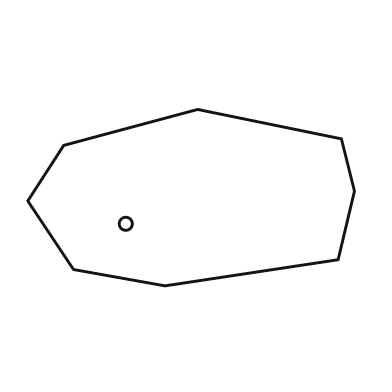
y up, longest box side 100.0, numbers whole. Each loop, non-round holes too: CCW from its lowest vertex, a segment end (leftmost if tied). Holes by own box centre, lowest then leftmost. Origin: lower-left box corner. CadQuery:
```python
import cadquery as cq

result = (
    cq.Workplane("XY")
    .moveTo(42.0, 0.0)
    .lineTo(95.0, 8.0)
    .lineTo(100.0, 29.0)
    .lineTo(96.0, 45.0)
    .lineTo(52.0, 54.0)
    .lineTo(11.0, 43.0)
    .lineTo(0.0, 26.0)
    .lineTo(14.0, 5.0)
    .close()
    .moveTo(30.0, 19.0)
    .circle(2.0)
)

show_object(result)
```